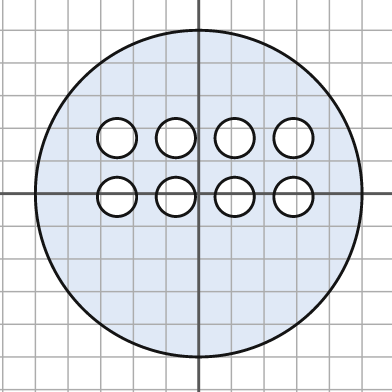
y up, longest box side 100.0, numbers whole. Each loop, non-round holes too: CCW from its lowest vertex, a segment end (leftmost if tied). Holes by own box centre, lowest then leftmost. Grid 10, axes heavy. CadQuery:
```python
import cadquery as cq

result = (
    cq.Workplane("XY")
    .moveTo(0.0, 0.0)
    .circle(50.0)
    .moveTo(-25.0, -1.0)
    .circle(6.0)
    .moveTo(-7.0, -1.0)
    .circle(6.0)
    .moveTo(11.0, -1.0)
    .circle(6.0)
    .moveTo(29.0, -1.0)
    .circle(6.0)
    .moveTo(-25.0, 17.0)
    .circle(6.0)
    .moveTo(-7.0, 17.0)
    .circle(6.0)
    .moveTo(11.0, 17.0)
    .circle(6.0)
    .moveTo(29.0, 17.0)
    .circle(6.0)
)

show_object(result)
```